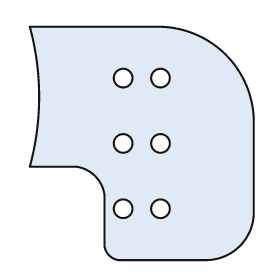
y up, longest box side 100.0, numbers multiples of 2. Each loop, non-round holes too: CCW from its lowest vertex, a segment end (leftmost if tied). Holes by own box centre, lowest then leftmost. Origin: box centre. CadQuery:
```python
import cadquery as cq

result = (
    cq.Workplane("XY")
    .moveTo(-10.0, -50.0)
    .lineTo(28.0, -50.0)
    .threePointArc((42.0, -44.0), (48.0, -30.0))
    .lineTo(48.0, 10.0)
    .threePointArc((36.0, 38.0), (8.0, 50.0))
    .lineTo(-48.0, 50.0)
    .threePointArc((-44.0, 20.0), (-48.0, -10.0))
    .lineTo(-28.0, -10.0)
    .threePointArc((-20.0, -14.0), (-16.0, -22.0))
    .lineTo(-16.0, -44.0)
    .threePointArc((-14.0, -48.0), (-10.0, -50.0))
    .close()
    .moveTo(-8.0, -28.0)
    .circle(4.0)
    .moveTo(8.0, -28.0)
    .circle(4.0)
    .moveTo(-8.0, 0.0)
    .circle(4.0)
    .moveTo(8.0, 0.0)
    .circle(4.0)
    .moveTo(-8.0, 28.0)
    .circle(4.0)
    .moveTo(8.0, 28.0)
    .circle(4.0)
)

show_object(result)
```